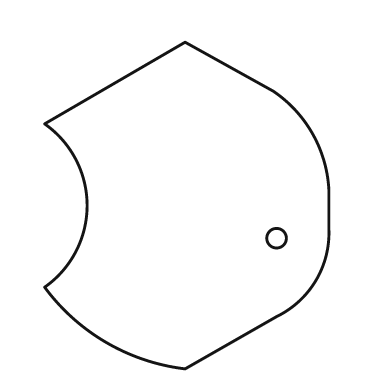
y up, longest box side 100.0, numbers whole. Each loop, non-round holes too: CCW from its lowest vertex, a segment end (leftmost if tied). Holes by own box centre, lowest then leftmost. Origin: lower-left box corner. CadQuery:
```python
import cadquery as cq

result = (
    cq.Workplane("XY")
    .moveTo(43.0, 0.0)
    .lineTo(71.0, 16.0)
    .threePointArc((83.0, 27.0), (87.0, 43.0))
    .lineTo(87.0, 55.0)
    .threePointArc((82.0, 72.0), (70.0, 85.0))
    .lineTo(43.0, 100.0)
    .lineTo(0.0, 75.0)
    .threePointArc((13.0, 50.0), (0.0, 25.0))
    .threePointArc((19.0, 8.0), (43.0, 0.0))
    .close()
    .moveTo(71.0, 40.0)
    .circle(3.0)
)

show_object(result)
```